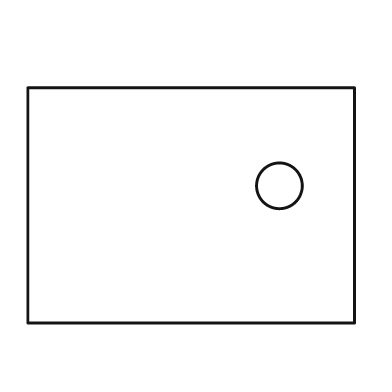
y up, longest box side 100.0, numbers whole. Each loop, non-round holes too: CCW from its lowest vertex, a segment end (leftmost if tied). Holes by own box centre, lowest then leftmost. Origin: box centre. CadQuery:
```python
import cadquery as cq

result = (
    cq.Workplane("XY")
    .moveTo(-50.0, -36.0)
    .lineTo(50.0, -36.0)
    .lineTo(50.0, 36.0)
    .lineTo(-50.0, 36.0)
    .close()
    .moveTo(27.0, 6.0)
    .circle(7.0)
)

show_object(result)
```